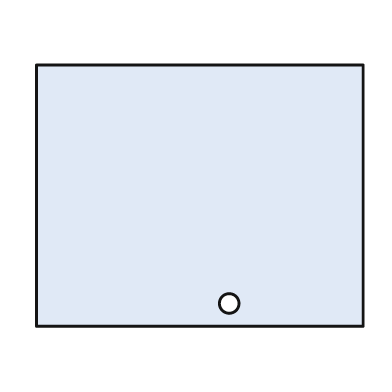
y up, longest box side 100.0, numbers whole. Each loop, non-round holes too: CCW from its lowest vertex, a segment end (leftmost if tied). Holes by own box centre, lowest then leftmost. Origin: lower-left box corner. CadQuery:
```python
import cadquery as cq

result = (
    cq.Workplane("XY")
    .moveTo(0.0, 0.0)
    .lineTo(100.0, 0.0)
    .lineTo(100.0, 80.0)
    .lineTo(0.0, 80.0)
    .close()
    .moveTo(59.0, 7.0)
    .circle(3.0)
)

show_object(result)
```